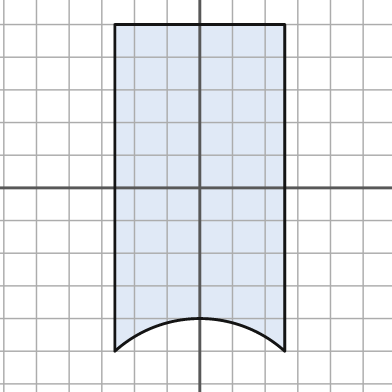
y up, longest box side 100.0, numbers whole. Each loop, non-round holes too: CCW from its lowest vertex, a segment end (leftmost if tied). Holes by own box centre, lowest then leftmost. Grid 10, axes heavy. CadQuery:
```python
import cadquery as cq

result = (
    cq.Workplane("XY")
    .moveTo(-26.0, -50.0)
    .threePointArc((0.0, -40.0), (26.0, -50.0))
    .lineTo(26.0, 50.0)
    .lineTo(-26.0, 50.0)
    .close()
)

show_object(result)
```